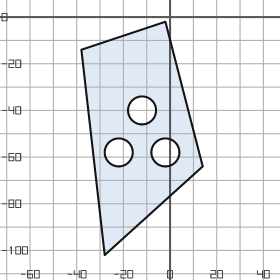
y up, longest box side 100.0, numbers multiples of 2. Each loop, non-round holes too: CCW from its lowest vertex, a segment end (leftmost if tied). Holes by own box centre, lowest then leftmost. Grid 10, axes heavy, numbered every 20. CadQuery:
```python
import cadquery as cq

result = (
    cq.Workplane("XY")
    .moveTo(-28.0, -102.0)
    .lineTo(14.0, -64.0)
    .lineTo(-2.0, -2.0)
    .lineTo(-38.0, -14.0)
    .close()
    .moveTo(-22.0, -58.0)
    .circle(6.0)
    .moveTo(-2.0, -58.0)
    .circle(6.0)
    .moveTo(-12.0, -40.0)
    .circle(6.0)
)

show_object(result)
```